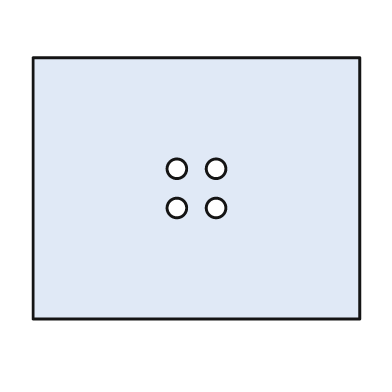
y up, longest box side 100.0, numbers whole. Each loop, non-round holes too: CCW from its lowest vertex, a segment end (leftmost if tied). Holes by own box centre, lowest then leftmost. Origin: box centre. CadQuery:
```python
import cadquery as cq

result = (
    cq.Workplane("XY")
    .moveTo(-50.0, -40.0)
    .lineTo(50.0, -40.0)
    .lineTo(50.0, 40.0)
    .lineTo(-50.0, 40.0)
    .close()
    .moveTo(-6.0, -6.0)
    .circle(3.0)
    .moveTo(6.0, -6.0)
    .circle(3.0)
    .moveTo(-6.0, 6.0)
    .circle(3.0)
    .moveTo(6.0, 6.0)
    .circle(3.0)
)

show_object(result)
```